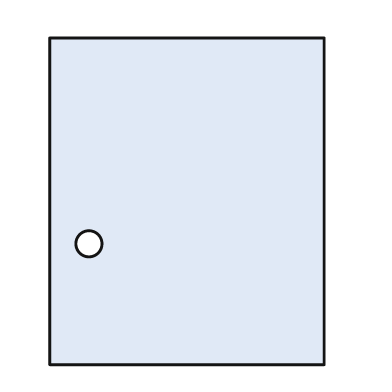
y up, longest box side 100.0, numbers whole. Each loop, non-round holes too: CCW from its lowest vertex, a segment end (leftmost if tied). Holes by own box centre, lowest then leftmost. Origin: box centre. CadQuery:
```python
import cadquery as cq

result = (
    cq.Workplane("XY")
    .moveTo(-42.0, -50.0)
    .lineTo(42.0, -50.0)
    .lineTo(42.0, 50.0)
    .lineTo(-42.0, 50.0)
    .close()
    .moveTo(-30.0, -13.0)
    .circle(4.0)
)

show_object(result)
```